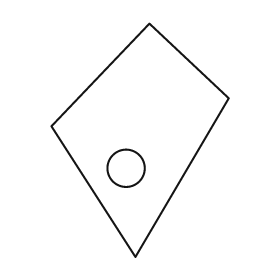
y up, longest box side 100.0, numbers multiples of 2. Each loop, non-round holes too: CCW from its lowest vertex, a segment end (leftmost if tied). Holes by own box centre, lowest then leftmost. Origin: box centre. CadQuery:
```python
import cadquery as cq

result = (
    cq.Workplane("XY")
    .moveTo(-2.0, -50.0)
    .lineTo(38.0, 18.0)
    .lineTo(4.0, 50.0)
    .lineTo(-38.0, 6.0)
    .close()
    .moveTo(-6.0, -12.0)
    .circle(8.0)
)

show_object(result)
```